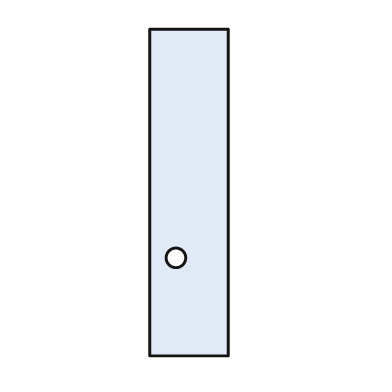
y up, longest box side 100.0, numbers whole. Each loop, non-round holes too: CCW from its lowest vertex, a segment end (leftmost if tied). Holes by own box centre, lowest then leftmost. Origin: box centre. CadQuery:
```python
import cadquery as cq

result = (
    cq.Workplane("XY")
    .moveTo(-12.0, -50.0)
    .lineTo(12.0, -50.0)
    .lineTo(12.0, 50.0)
    .lineTo(-12.0, 50.0)
    .close()
    .moveTo(-4.0, -20.0)
    .circle(3.0)
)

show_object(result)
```